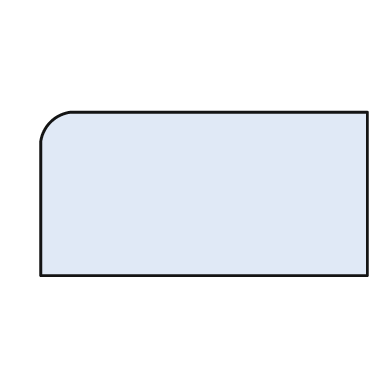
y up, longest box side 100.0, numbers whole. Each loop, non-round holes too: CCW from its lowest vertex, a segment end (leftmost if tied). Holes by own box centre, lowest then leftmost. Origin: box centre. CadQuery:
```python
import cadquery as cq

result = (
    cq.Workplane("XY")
    .moveTo(-50.0, -25.0)
    .lineTo(50.0, -25.0)
    .lineTo(50.0, 25.0)
    .lineTo(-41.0, 25.0)
    .threePointArc((-47.0, 22.0), (-50.0, 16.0))
    .close()
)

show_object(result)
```